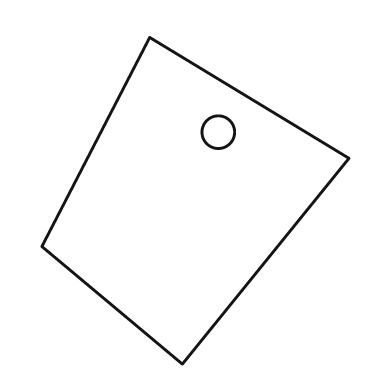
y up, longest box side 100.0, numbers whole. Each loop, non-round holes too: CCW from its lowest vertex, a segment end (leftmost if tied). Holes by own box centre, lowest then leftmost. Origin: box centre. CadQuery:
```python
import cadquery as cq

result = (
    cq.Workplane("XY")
    .moveTo(-4.0, -50.0)
    .lineTo(47.0, 13.0)
    .lineTo(-14.0, 50.0)
    .lineTo(-47.0, -14.0)
    .close()
    .moveTo(7.0, 21.0)
    .circle(5.0)
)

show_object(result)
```